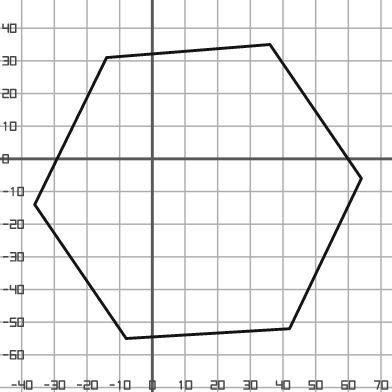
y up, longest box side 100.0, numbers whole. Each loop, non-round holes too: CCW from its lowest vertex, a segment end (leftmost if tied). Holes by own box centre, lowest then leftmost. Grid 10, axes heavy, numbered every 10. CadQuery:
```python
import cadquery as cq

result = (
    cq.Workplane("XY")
    .moveTo(-8.0, -55.0)
    .lineTo(42.0, -52.0)
    .lineTo(64.0, -6.0)
    .lineTo(36.0, 35.0)
    .lineTo(-14.0, 31.0)
    .lineTo(-36.0, -14.0)
    .close()
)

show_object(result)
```